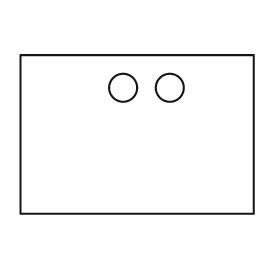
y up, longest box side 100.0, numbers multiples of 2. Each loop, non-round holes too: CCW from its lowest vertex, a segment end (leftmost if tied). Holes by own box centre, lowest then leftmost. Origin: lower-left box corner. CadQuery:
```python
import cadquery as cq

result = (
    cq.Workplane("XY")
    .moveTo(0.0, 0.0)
    .lineTo(100.0, 0.0)
    .lineTo(100.0, 68.0)
    .lineTo(0.0, 68.0)
    .close()
    .moveTo(44.0, 54.0)
    .circle(6.0)
    .moveTo(64.0, 54.0)
    .circle(6.0)
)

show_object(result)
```